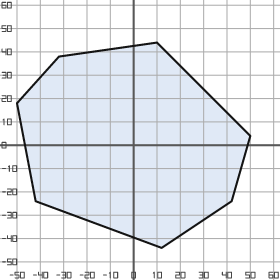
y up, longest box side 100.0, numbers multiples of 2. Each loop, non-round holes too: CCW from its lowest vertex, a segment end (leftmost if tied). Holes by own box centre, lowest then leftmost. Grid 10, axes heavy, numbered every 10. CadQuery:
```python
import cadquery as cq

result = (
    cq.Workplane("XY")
    .moveTo(12.0, -44.0)
    .lineTo(42.0, -24.0)
    .lineTo(50.0, 4.0)
    .lineTo(10.0, 44.0)
    .lineTo(-32.0, 38.0)
    .lineTo(-50.0, 18.0)
    .lineTo(-42.0, -24.0)
    .close()
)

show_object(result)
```